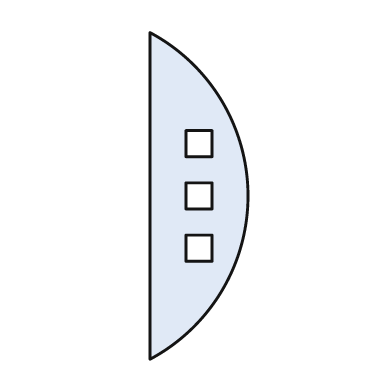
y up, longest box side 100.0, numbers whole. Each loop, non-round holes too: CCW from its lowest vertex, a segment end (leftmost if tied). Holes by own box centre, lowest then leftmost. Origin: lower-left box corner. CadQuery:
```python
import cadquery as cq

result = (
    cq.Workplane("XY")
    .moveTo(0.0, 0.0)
    .threePointArc((30.0, 50.0), (0.0, 100.0))
    .close()
    .moveTo(11.0, 30.0)
    .lineTo(19.0, 30.0)
    .lineTo(19.0, 38.0)
    .lineTo(11.0, 38.0)
    .close()
    .moveTo(11.0, 46.0)
    .lineTo(19.0, 46.0)
    .lineTo(19.0, 54.0)
    .lineTo(11.0, 54.0)
    .close()
    .moveTo(11.0, 62.0)
    .lineTo(19.0, 62.0)
    .lineTo(19.0, 70.0)
    .lineTo(11.0, 70.0)
    .close()
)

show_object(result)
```